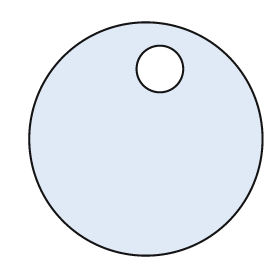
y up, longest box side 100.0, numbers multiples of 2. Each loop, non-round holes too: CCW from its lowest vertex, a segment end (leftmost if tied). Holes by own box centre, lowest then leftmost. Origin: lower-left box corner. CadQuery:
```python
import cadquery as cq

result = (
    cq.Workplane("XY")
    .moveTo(50.0, 50.0)
    .circle(50.0)
    .moveTo(56.0, 80.0)
    .circle(10.0)
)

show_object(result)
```